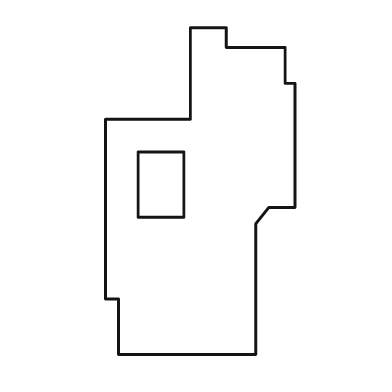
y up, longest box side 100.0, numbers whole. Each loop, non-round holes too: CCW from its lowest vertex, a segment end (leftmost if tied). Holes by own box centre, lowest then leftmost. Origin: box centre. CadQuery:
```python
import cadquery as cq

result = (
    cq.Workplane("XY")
    .moveTo(-25.0, -50.0)
    .lineTo(17.0, -50.0)
    .lineTo(17.0, -10.0)
    .lineTo(21.0, -5.0)
    .lineTo(29.0, -5.0)
    .lineTo(29.0, 33.0)
    .lineTo(26.0, 33.0)
    .lineTo(26.0, 44.0)
    .lineTo(8.0, 44.0)
    .lineTo(8.0, 50.0)
    .lineTo(-3.0, 50.0)
    .lineTo(-3.0, 22.0)
    .lineTo(-29.0, 22.0)
    .lineTo(-29.0, -33.0)
    .lineTo(-25.0, -33.0)
    .close()
    .moveTo(-19.0, -8.0)
    .lineTo(-5.0, -8.0)
    .lineTo(-5.0, 12.0)
    .lineTo(-19.0, 12.0)
    .close()
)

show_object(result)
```